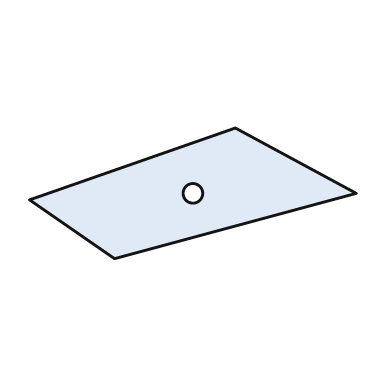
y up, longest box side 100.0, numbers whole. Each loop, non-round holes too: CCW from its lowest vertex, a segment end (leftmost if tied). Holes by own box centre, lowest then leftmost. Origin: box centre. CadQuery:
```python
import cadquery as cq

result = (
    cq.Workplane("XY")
    .moveTo(-24.0, -20.0)
    .lineTo(50.0, 0.0)
    .lineTo(13.0, 20.0)
    .lineTo(-50.0, -2.0)
    .close()
    .moveTo(0.0, 0.0)
    .circle(3.0)
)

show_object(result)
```